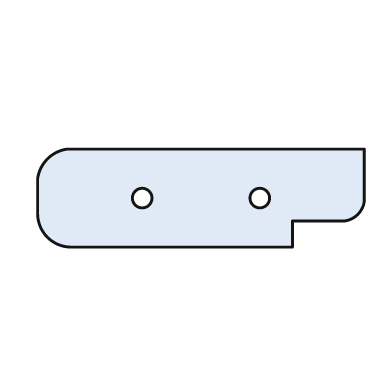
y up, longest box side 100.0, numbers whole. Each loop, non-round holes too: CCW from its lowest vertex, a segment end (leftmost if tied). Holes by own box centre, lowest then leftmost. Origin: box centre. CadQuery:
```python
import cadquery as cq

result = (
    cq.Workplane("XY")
    .moveTo(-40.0, -15.0)
    .lineTo(28.0, -15.0)
    .lineTo(28.0, -7.0)
    .lineTo(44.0, -7.0)
    .threePointArc((48.0, -5.0), (50.0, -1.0))
    .lineTo(50.0, 15.0)
    .lineTo(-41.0, 15.0)
    .threePointArc((-47.0, 12.0), (-50.0, 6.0))
    .lineTo(-50.0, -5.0)
    .threePointArc((-47.0, -12.0), (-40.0, -15.0))
    .close()
    .moveTo(-18.0, 0.0)
    .circle(3.0)
    .moveTo(18.0, 0.0)
    .circle(3.0)
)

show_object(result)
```